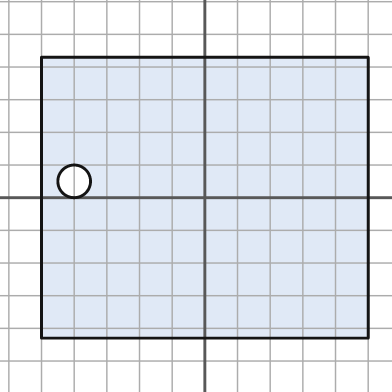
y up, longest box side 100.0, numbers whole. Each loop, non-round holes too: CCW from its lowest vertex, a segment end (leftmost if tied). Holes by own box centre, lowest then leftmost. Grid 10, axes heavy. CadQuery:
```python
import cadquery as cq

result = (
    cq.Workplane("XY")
    .moveTo(-50.0, -43.0)
    .lineTo(50.0, -43.0)
    .lineTo(50.0, 43.0)
    .lineTo(-50.0, 43.0)
    .close()
    .moveTo(-40.0, 5.0)
    .circle(5.0)
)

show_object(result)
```